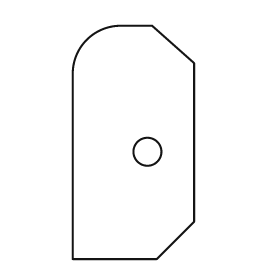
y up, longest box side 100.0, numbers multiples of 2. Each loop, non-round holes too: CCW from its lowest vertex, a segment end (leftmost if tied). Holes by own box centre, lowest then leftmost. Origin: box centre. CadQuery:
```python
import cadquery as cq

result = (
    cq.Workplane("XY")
    .moveTo(-26.0, -50.0)
    .lineTo(10.0, -50.0)
    .lineTo(26.0, -34.0)
    .lineTo(26.0, 34.0)
    .lineTo(8.0, 50.0)
    .lineTo(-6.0, 50.0)
    .threePointArc((-20.0, 44.0), (-26.0, 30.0))
    .close()
    .moveTo(6.0, -4.0)
    .circle(6.0)
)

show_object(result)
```